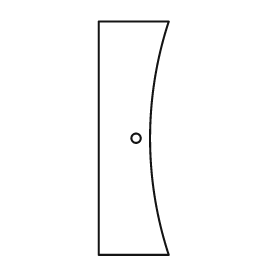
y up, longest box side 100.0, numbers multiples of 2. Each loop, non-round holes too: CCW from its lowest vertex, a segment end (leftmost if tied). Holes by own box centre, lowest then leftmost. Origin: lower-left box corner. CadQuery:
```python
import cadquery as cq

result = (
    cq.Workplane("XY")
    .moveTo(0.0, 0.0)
    .lineTo(30.0, 0.0)
    .threePointArc((22.0, 50.0), (30.0, 100.0))
    .lineTo(0.0, 100.0)
    .close()
    .moveTo(16.0, 50.0)
    .circle(2.0)
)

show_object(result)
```